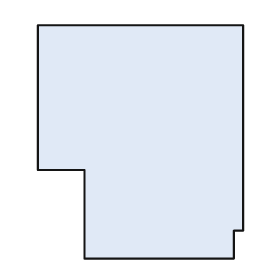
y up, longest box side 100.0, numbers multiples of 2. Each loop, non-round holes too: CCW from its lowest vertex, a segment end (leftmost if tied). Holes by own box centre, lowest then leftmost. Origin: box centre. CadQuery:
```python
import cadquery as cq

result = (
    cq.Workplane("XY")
    .moveTo(-24.0, -50.0)
    .lineTo(40.0, -50.0)
    .lineTo(40.0, -38.0)
    .lineTo(44.0, -38.0)
    .lineTo(44.0, 50.0)
    .lineTo(-44.0, 50.0)
    .lineTo(-44.0, -12.0)
    .lineTo(-24.0, -12.0)
    .close()
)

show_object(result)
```